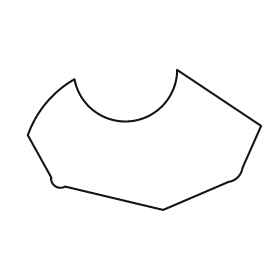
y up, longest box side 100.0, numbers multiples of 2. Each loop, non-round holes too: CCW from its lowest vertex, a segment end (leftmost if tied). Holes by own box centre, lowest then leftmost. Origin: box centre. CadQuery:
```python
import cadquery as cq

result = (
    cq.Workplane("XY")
    .moveTo(8.0, -30.0)
    .lineTo(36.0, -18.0)
    .threePointArc((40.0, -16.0), (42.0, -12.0))
    .lineTo(50.0, 6.0)
    .lineTo(14.0, 30.0)
    .threePointArc((-6.0, 8.0), (-30.0, 26.0))
    .threePointArc((-42.0, 16.0), (-50.0, 2.0))
    .lineTo(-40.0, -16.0)
    .threePointArc((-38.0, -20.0), (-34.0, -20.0))
    .close()
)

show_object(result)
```